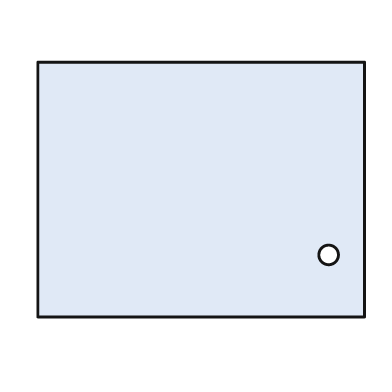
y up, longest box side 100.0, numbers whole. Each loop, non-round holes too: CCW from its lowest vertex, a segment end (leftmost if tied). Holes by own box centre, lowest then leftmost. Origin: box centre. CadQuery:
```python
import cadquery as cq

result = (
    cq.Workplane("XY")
    .moveTo(-50.0, -39.0)
    .lineTo(50.0, -39.0)
    .lineTo(50.0, 39.0)
    .lineTo(-50.0, 39.0)
    .close()
    .moveTo(39.0, -20.0)
    .circle(3.0)
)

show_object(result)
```